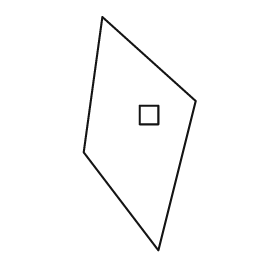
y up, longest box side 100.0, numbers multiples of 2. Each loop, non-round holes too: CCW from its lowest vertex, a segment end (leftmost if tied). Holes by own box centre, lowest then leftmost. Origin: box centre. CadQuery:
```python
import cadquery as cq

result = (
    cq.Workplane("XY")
    .moveTo(8.0, -50.0)
    .lineTo(24.0, 14.0)
    .lineTo(-16.0, 50.0)
    .lineTo(-24.0, -8.0)
    .close()
    .moveTo(0.0, 4.0)
    .lineTo(8.0, 4.0)
    .lineTo(8.0, 12.0)
    .lineTo(0.0, 12.0)
    .close()
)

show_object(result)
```